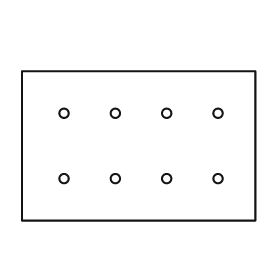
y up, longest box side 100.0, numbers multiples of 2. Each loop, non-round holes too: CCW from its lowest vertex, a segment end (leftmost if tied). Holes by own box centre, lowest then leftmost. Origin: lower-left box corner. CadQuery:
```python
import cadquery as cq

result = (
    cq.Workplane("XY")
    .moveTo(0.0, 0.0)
    .lineTo(100.0, 0.0)
    .lineTo(100.0, 64.0)
    .lineTo(0.0, 64.0)
    .close()
    .moveTo(18.0, 18.0)
    .circle(2.0)
    .moveTo(40.0, 18.0)
    .circle(2.0)
    .moveTo(62.0, 18.0)
    .circle(2.0)
    .moveTo(84.0, 18.0)
    .circle(2.0)
    .moveTo(18.0, 46.0)
    .circle(2.0)
    .moveTo(40.0, 46.0)
    .circle(2.0)
    .moveTo(62.0, 46.0)
    .circle(2.0)
    .moveTo(84.0, 46.0)
    .circle(2.0)
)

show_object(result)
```